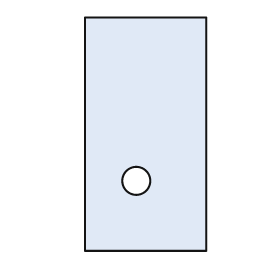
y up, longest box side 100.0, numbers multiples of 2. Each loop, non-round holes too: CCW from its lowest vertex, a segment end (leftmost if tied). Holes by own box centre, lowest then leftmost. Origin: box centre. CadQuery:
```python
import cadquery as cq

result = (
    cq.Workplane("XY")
    .moveTo(-26.0, -50.0)
    .lineTo(26.0, -50.0)
    .lineTo(26.0, 50.0)
    .lineTo(-26.0, 50.0)
    .close()
    .moveTo(-4.0, -20.0)
    .circle(6.0)
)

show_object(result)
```